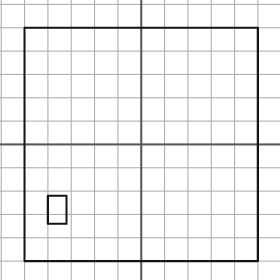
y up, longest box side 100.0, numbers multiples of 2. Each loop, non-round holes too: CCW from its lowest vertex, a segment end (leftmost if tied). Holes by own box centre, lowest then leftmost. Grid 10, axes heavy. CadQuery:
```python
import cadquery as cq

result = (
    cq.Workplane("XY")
    .moveTo(-50.0, -50.0)
    .lineTo(50.0, -50.0)
    .lineTo(50.0, 50.0)
    .lineTo(-50.0, 50.0)
    .close()
    .moveTo(-40.0, -34.0)
    .lineTo(-32.0, -34.0)
    .lineTo(-32.0, -22.0)
    .lineTo(-40.0, -22.0)
    .close()
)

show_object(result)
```